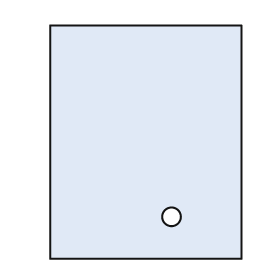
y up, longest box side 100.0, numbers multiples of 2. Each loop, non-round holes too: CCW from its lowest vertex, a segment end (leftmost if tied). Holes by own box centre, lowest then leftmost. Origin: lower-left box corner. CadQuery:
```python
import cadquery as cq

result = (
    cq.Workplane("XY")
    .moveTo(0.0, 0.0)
    .lineTo(82.0, 0.0)
    .lineTo(82.0, 100.0)
    .lineTo(0.0, 100.0)
    .close()
    .moveTo(52.0, 18.0)
    .circle(4.0)
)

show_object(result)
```